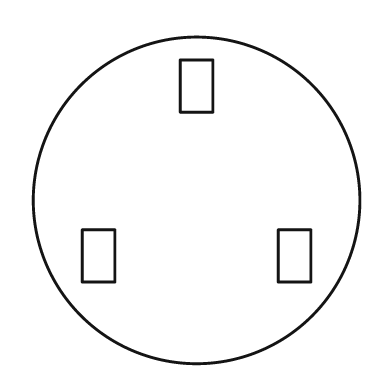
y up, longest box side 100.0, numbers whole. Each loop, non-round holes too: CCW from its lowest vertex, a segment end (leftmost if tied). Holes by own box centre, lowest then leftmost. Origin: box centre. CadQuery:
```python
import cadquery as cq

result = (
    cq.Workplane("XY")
    .moveTo(0.0, 0.0)
    .circle(50.0)
    .moveTo(-35.0, -25.0)
    .lineTo(-25.0, -25.0)
    .lineTo(-25.0, -9.0)
    .lineTo(-35.0, -9.0)
    .close()
    .moveTo(25.0, -25.0)
    .lineTo(35.0, -25.0)
    .lineTo(35.0, -9.0)
    .lineTo(25.0, -9.0)
    .close()
    .moveTo(-5.0, 27.0)
    .lineTo(5.0, 27.0)
    .lineTo(5.0, 43.0)
    .lineTo(-5.0, 43.0)
    .close()
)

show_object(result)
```